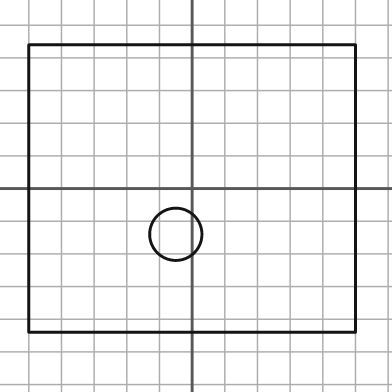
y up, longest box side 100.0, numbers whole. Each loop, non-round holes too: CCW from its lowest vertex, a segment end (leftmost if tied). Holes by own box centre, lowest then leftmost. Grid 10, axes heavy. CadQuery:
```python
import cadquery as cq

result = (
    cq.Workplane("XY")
    .moveTo(-50.0, -44.0)
    .lineTo(50.0, -44.0)
    .lineTo(50.0, 44.0)
    .lineTo(-50.0, 44.0)
    .close()
    .moveTo(-5.0, -14.0)
    .circle(8.0)
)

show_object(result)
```